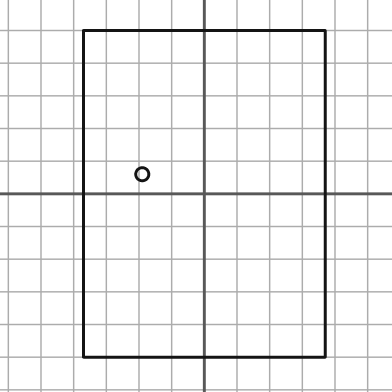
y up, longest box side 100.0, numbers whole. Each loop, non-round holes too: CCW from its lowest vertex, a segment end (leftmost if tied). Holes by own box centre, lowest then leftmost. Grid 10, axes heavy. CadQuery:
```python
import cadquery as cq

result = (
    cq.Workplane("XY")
    .moveTo(-37.0, -50.0)
    .lineTo(37.0, -50.0)
    .lineTo(37.0, 50.0)
    .lineTo(-37.0, 50.0)
    .close()
    .moveTo(-19.0, 6.0)
    .circle(2.0)
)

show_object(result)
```